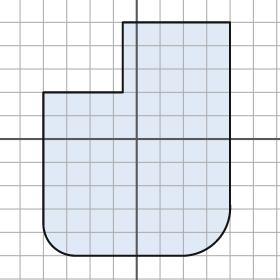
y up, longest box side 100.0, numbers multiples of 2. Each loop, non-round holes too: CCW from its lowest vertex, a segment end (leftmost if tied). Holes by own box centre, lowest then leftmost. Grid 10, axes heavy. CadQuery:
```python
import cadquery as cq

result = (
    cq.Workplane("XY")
    .moveTo(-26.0, -50.0)
    .lineTo(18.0, -50.0)
    .threePointArc((34.0, -44.0), (40.0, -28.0))
    .lineTo(40.0, 50.0)
    .lineTo(-6.0, 50.0)
    .lineTo(-6.0, 20.0)
    .lineTo(-40.0, 20.0)
    .lineTo(-40.0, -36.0)
    .threePointArc((-36.0, -46.0), (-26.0, -50.0))
    .close()
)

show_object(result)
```